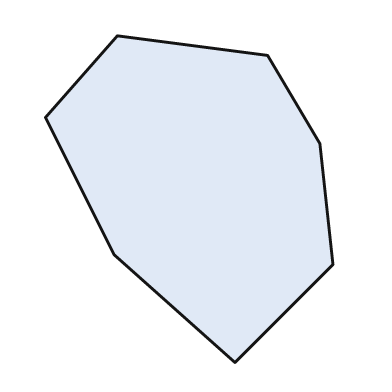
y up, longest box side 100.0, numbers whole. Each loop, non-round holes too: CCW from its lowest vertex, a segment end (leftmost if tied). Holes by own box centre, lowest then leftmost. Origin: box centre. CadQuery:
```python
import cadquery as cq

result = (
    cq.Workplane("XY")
    .moveTo(14.0, -50.0)
    .lineTo(44.0, -20.0)
    .lineTo(40.0, 17.0)
    .lineTo(24.0, 44.0)
    .lineTo(-22.0, 50.0)
    .lineTo(-44.0, 25.0)
    .lineTo(-23.0, -17.0)
    .close()
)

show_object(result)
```